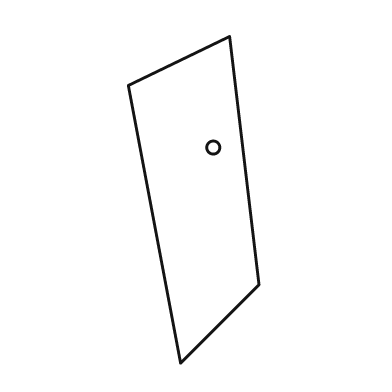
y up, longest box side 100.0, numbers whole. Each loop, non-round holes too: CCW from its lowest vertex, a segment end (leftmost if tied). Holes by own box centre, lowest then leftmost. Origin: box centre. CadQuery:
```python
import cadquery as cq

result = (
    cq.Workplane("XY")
    .moveTo(-4.0, -50.0)
    .lineTo(20.0, -26.0)
    .lineTo(11.0, 50.0)
    .lineTo(-20.0, 35.0)
    .close()
    .moveTo(6.0, 16.0)
    .circle(2.0)
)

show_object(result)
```